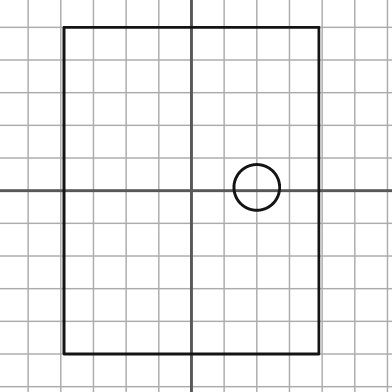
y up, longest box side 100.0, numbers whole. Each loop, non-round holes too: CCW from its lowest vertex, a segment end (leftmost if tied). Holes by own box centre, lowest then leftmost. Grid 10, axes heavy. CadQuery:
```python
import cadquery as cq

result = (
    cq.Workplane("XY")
    .moveTo(-39.0, -50.0)
    .lineTo(39.0, -50.0)
    .lineTo(39.0, 50.0)
    .lineTo(-39.0, 50.0)
    .close()
    .moveTo(20.0, 1.0)
    .circle(7.0)
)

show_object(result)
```